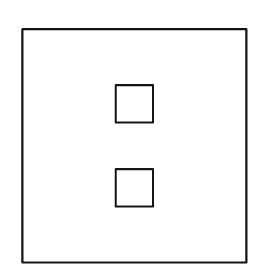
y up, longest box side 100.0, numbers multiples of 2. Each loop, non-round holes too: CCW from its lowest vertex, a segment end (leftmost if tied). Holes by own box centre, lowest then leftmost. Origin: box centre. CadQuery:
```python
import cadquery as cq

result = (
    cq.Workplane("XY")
    .moveTo(-48.0, -50.0)
    .lineTo(48.0, -50.0)
    .lineTo(48.0, 50.0)
    .lineTo(-48.0, 50.0)
    .close()
    .moveTo(-8.0, -26.0)
    .lineTo(8.0, -26.0)
    .lineTo(8.0, -10.0)
    .lineTo(-8.0, -10.0)
    .close()
    .moveTo(-8.0, 10.0)
    .lineTo(8.0, 10.0)
    .lineTo(8.0, 26.0)
    .lineTo(-8.0, 26.0)
    .close()
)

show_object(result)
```